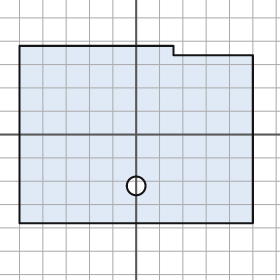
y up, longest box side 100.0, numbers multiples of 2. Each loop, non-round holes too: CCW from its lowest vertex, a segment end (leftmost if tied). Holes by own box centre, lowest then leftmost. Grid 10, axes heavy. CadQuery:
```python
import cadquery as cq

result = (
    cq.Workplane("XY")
    .moveTo(-50.0, -38.0)
    .lineTo(50.0, -38.0)
    .lineTo(50.0, 34.0)
    .lineTo(16.0, 34.0)
    .lineTo(16.0, 38.0)
    .lineTo(-50.0, 38.0)
    .close()
    .moveTo(0.0, -22.0)
    .circle(4.0)
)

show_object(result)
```